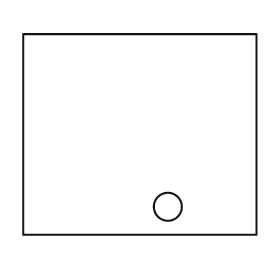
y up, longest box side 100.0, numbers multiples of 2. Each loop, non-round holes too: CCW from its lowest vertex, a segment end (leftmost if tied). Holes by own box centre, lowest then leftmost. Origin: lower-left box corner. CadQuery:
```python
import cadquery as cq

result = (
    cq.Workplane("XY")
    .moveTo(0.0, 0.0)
    .lineTo(100.0, 0.0)
    .lineTo(100.0, 86.0)
    .lineTo(0.0, 86.0)
    .close()
    .moveTo(62.0, 12.0)
    .circle(6.0)
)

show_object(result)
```